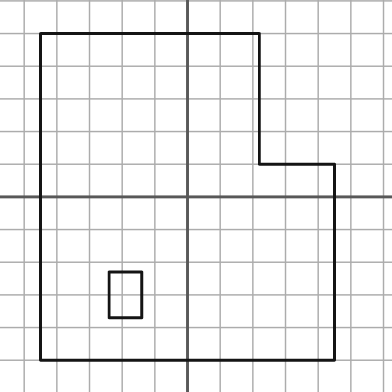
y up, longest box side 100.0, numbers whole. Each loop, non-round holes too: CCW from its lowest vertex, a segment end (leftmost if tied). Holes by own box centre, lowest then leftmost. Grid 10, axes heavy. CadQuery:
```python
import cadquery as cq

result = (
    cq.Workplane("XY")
    .moveTo(-45.0, -50.0)
    .lineTo(45.0, -50.0)
    .lineTo(45.0, 10.0)
    .lineTo(22.0, 10.0)
    .lineTo(22.0, 50.0)
    .lineTo(-45.0, 50.0)
    .close()
    .moveTo(-24.0, -37.0)
    .lineTo(-14.0, -37.0)
    .lineTo(-14.0, -23.0)
    .lineTo(-24.0, -23.0)
    .close()
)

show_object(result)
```